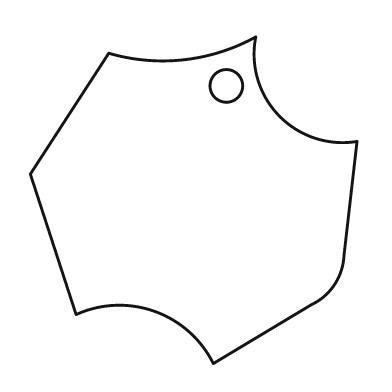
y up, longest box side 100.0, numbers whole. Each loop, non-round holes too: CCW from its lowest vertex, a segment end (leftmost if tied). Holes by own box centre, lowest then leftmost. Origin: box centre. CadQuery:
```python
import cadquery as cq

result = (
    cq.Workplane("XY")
    .moveTo(6.0, -50.0)
    .lineTo(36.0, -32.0)
    .threePointArc((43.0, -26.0), (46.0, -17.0))
    .lineTo(50.0, 18.0)
    .threePointArc((26.0, 26.0), (19.0, 50.0))
    .threePointArc((-3.0, 43.0), (-26.0, 45.0))
    .lineTo(-50.0, 8.0)
    .lineTo(-36.0, -35.0)
    .threePointArc((-12.0, -34.0), (6.0, -50.0))
    .close()
    .moveTo(10.0, 35.0)
    .circle(5.0)
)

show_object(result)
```